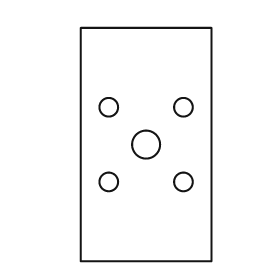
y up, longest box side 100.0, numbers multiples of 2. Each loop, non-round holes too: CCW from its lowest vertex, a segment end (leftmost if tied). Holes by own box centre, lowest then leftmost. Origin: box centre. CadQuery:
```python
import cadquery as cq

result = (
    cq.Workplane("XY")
    .moveTo(-28.0, -50.0)
    .lineTo(28.0, -50.0)
    .lineTo(28.0, 50.0)
    .lineTo(-28.0, 50.0)
    .close()
    .moveTo(-16.0, -16.0)
    .circle(4.0)
    .moveTo(16.0, -16.0)
    .circle(4.0)
    .moveTo(0.0, 0.0)
    .circle(6.0)
    .moveTo(-16.0, 16.0)
    .circle(4.0)
    .moveTo(16.0, 16.0)
    .circle(4.0)
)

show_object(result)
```